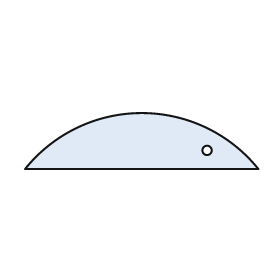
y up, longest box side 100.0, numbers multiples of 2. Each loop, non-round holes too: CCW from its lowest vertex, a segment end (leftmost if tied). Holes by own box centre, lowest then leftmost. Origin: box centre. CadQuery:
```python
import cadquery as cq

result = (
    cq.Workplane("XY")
    .moveTo(-50.0, -12.0)
    .lineTo(50.0, -12.0)
    .threePointArc((0.0, 12.0), (-50.0, -12.0))
    .close()
    .moveTo(28.0, -4.0)
    .circle(2.0)
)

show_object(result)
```